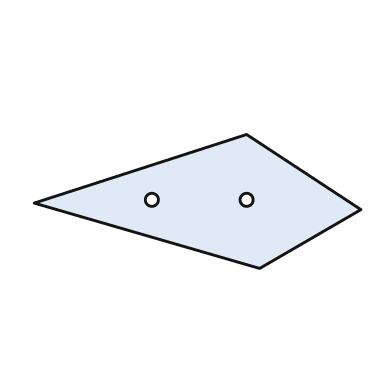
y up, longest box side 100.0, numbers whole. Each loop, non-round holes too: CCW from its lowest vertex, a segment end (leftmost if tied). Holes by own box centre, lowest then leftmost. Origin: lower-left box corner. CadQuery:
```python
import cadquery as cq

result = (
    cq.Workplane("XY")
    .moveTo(69.0, 0.0)
    .lineTo(100.0, 18.0)
    .lineTo(65.0, 41.0)
    .lineTo(0.0, 20.0)
    .close()
    .moveTo(36.0, 21.0)
    .circle(2.0)
    .moveTo(65.0, 21.0)
    .circle(2.0)
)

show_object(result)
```